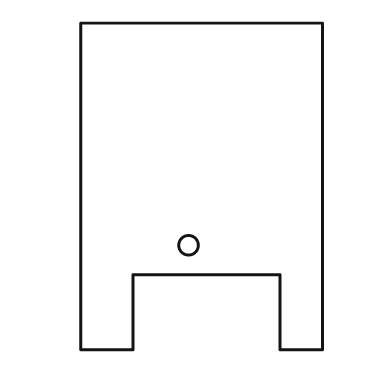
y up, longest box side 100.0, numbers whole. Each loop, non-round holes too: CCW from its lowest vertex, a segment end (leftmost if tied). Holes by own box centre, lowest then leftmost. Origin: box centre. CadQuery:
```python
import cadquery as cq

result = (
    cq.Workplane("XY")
    .moveTo(-37.0, -50.0)
    .lineTo(-21.0, -50.0)
    .lineTo(-21.0, -27.0)
    .lineTo(24.0, -27.0)
    .lineTo(24.0, -50.0)
    .lineTo(37.0, -50.0)
    .lineTo(37.0, 50.0)
    .lineTo(-37.0, 50.0)
    .close()
    .moveTo(-4.0, -18.0)
    .circle(3.0)
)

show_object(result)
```